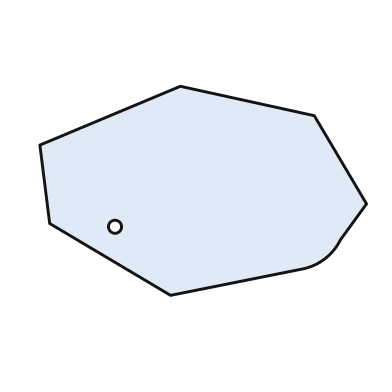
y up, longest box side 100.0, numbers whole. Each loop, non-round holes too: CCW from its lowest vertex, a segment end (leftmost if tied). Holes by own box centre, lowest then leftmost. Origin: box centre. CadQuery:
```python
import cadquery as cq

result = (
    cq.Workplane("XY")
    .moveTo(-10.0, -32.0)
    .lineTo(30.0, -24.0)
    .threePointArc((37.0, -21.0), (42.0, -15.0))
    .lineTo(50.0, -4.0)
    .lineTo(34.0, 23.0)
    .lineTo(-7.0, 32.0)
    .lineTo(-50.0, 14.0)
    .lineTo(-47.0, -10.0)
    .close()
    .moveTo(-27.0, -11.0)
    .circle(2.0)
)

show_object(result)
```